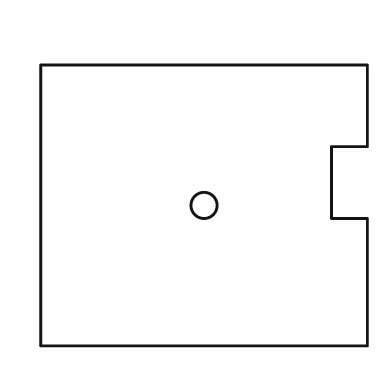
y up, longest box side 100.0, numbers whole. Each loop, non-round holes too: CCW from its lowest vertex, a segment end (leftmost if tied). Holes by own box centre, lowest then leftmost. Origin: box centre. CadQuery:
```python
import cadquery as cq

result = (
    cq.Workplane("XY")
    .moveTo(-50.0, -43.0)
    .lineTo(50.0, -43.0)
    .lineTo(50.0, -4.0)
    .lineTo(39.0, -4.0)
    .lineTo(39.0, 18.0)
    .lineTo(50.0, 18.0)
    .lineTo(50.0, 43.0)
    .lineTo(-50.0, 43.0)
    .close()
    .moveTo(0.0, 0.0)
    .circle(4.0)
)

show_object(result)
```